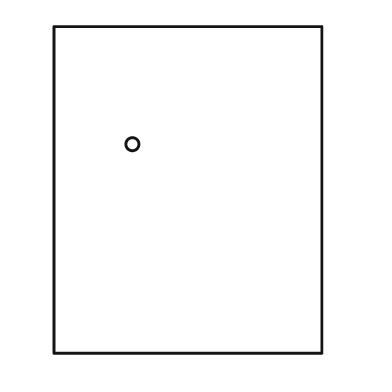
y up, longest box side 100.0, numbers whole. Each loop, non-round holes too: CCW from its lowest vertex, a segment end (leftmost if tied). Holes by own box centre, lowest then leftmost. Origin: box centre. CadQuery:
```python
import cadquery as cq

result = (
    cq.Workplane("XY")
    .moveTo(-41.0, -50.0)
    .lineTo(41.0, -50.0)
    .lineTo(41.0, 50.0)
    .lineTo(-41.0, 50.0)
    .close()
    .moveTo(-17.0, 14.0)
    .circle(2.0)
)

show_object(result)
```